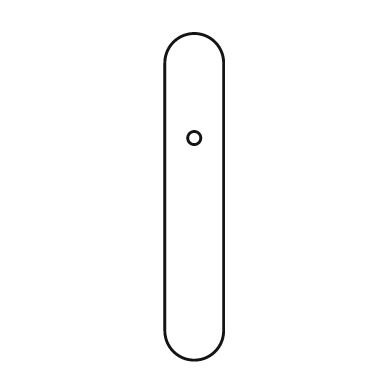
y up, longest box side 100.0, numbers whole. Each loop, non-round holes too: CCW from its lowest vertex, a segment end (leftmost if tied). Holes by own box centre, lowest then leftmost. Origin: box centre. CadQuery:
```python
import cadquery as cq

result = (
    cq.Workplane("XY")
    .moveTo(-9.0, -41.0)
    .threePointArc((0.0, -50.0), (9.0, -41.0))
    .lineTo(9.0, 41.0)
    .threePointArc((0.0, 50.0), (-9.0, 41.0))
    .close()
    .moveTo(0.0, 18.0)
    .circle(2.0)
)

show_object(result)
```